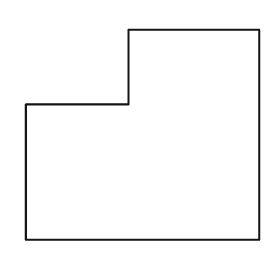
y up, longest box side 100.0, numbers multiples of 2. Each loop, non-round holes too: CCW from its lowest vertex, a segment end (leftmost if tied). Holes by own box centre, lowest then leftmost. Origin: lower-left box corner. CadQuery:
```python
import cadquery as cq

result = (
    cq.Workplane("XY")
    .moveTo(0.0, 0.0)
    .lineTo(100.0, 0.0)
    .lineTo(100.0, 90.0)
    .lineTo(44.0, 90.0)
    .lineTo(44.0, 58.0)
    .lineTo(0.0, 58.0)
    .close()
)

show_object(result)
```